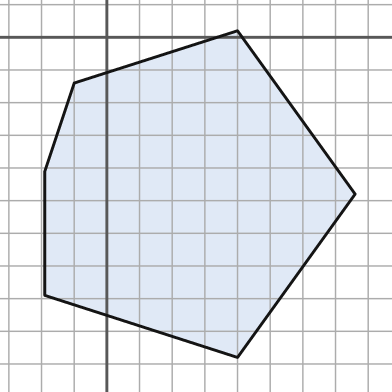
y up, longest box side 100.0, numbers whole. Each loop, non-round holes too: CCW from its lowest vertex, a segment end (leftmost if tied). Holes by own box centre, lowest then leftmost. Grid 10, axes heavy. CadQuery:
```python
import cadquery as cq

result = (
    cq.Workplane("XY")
    .moveTo(40.0, -98.0)
    .lineTo(76.0, -48.0)
    .lineTo(40.0, 2.0)
    .lineTo(-10.0, -14.0)
    .lineTo(-19.0, -41.0)
    .lineTo(-19.0, -79.0)
    .close()
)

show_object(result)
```